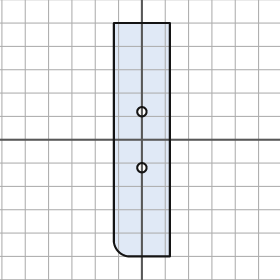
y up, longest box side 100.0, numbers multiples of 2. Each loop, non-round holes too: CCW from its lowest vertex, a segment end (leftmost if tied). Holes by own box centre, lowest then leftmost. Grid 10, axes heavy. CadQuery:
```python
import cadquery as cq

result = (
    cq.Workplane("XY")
    .moveTo(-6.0, -50.0)
    .lineTo(12.0, -50.0)
    .lineTo(12.0, 50.0)
    .lineTo(-12.0, 50.0)
    .lineTo(-12.0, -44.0)
    .threePointArc((-10.0, -48.0), (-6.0, -50.0))
    .close()
    .moveTo(0.0, -12.0)
    .circle(2.0)
    .moveTo(0.0, 12.0)
    .circle(2.0)
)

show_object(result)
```